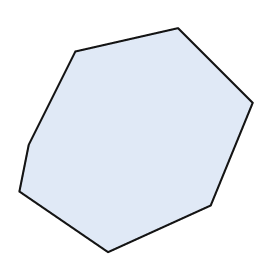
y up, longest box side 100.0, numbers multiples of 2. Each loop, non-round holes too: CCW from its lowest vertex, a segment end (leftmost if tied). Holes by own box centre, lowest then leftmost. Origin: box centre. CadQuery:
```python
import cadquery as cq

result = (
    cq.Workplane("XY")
    .moveTo(-12.0, -48.0)
    .lineTo(32.0, -28.0)
    .lineTo(50.0, 16.0)
    .lineTo(18.0, 48.0)
    .lineTo(-26.0, 38.0)
    .lineTo(-46.0, -2.0)
    .lineTo(-50.0, -22.0)
    .close()
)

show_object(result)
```